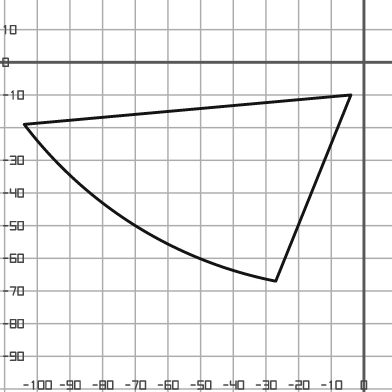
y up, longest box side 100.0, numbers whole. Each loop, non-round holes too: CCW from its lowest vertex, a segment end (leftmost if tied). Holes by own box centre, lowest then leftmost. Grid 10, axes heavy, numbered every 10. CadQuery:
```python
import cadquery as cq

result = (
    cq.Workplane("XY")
    .moveTo(-27.0, -67.0)
    .lineTo(-4.0, -10.0)
    .lineTo(-104.0, -19.0)
    .threePointArc((-70.0, -50.0), (-27.0, -67.0))
    .close()
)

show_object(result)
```